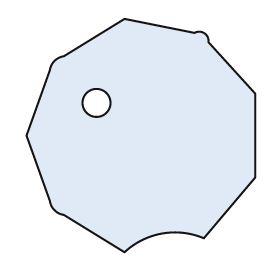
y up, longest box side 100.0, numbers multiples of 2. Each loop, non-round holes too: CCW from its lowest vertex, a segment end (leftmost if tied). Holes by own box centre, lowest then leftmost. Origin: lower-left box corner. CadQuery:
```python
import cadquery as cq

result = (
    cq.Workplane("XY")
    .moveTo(42.0, 0.0)
    .threePointArc((58.0, 8.0), (76.0, 6.0))
    .lineTo(98.0, 32.0)
    .lineTo(98.0, 68.0)
    .lineTo(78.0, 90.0)
    .threePointArc((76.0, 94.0), (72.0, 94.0))
    .lineTo(42.0, 100.0)
    .lineTo(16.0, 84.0)
    .threePointArc((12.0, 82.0), (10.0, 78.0))
    .lineTo(0.0, 50.0)
    .lineTo(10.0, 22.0)
    .threePointArc((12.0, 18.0), (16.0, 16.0))
    .close()
    .moveTo(30.0, 64.0)
    .circle(6.0)
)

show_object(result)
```